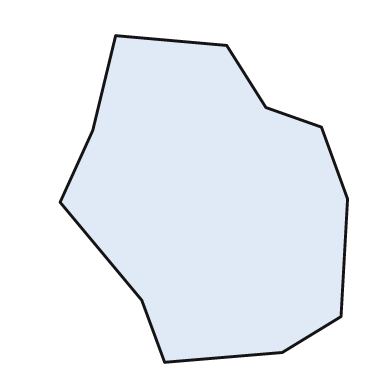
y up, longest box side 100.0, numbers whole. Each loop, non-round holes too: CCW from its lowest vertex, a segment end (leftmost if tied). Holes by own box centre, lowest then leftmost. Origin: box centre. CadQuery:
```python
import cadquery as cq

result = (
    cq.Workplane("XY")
    .moveTo(-12.0, -50.0)
    .lineTo(24.0, -47.0)
    .lineTo(42.0, -36.0)
    .lineTo(44.0, 0.0)
    .lineTo(36.0, 22.0)
    .lineTo(19.0, 28.0)
    .lineTo(7.0, 47.0)
    .lineTo(-27.0, 50.0)
    .lineTo(-34.0, 21.0)
    .lineTo(-44.0, -1.0)
    .lineTo(-19.0, -31.0)
    .close()
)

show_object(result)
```